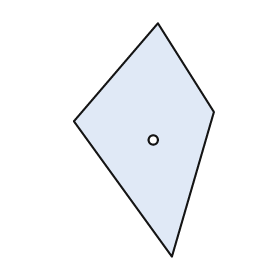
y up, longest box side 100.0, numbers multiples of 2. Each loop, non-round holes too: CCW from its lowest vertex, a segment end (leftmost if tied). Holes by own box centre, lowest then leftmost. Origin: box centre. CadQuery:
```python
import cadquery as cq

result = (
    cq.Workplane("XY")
    .moveTo(12.0, -50.0)
    .lineTo(30.0, 12.0)
    .lineTo(6.0, 50.0)
    .lineTo(-30.0, 8.0)
    .close()
    .moveTo(4.0, 0.0)
    .circle(2.0)
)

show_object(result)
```